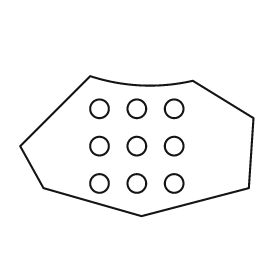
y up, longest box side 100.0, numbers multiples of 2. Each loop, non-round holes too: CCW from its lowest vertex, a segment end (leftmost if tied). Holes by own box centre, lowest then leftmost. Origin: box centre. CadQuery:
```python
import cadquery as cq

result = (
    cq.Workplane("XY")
    .moveTo(2.0, -30.0)
    .lineTo(48.0, -18.0)
    .lineTo(50.0, 12.0)
    .lineTo(24.0, 28.0)
    .threePointArc((2.0, 26.0), (-20.0, 30.0))
    .lineTo(-50.0, 0.0)
    .lineTo(-40.0, -18.0)
    .close()
    .moveTo(-16.0, -16.0)
    .circle(4.0)
    .moveTo(0.0, -16.0)
    .circle(4.0)
    .moveTo(16.0, -16.0)
    .circle(4.0)
    .moveTo(-16.0, 0.0)
    .circle(4.0)
    .moveTo(0.0, 0.0)
    .circle(4.0)
    .moveTo(16.0, 0.0)
    .circle(4.0)
    .moveTo(-16.0, 16.0)
    .circle(4.0)
    .moveTo(0.0, 16.0)
    .circle(4.0)
    .moveTo(16.0, 16.0)
    .circle(4.0)
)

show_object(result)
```